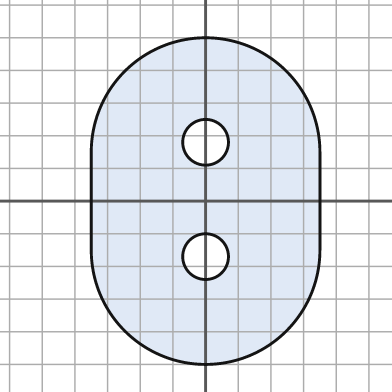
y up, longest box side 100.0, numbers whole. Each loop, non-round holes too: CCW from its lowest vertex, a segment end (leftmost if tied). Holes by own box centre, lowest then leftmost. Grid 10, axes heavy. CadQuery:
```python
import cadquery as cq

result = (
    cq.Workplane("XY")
    .moveTo(-35.0, -15.0)
    .threePointArc((0.0, -50.0), (35.0, -15.0))
    .lineTo(35.0, 15.0)
    .threePointArc((0.0, 50.0), (-35.0, 15.0))
    .close()
    .moveTo(0.0, -17.0)
    .circle(7.0)
    .moveTo(0.0, 18.0)
    .circle(7.0)
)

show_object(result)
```